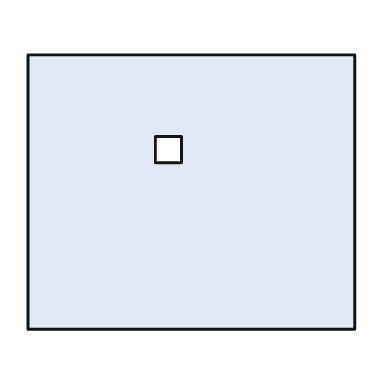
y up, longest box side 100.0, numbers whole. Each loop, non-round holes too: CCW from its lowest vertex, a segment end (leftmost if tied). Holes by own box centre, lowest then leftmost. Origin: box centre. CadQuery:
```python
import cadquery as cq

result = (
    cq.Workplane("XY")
    .moveTo(-50.0, -42.0)
    .lineTo(50.0, -42.0)
    .lineTo(50.0, 42.0)
    .lineTo(-50.0, 42.0)
    .close()
    .moveTo(-11.0, 9.0)
    .lineTo(-3.0, 9.0)
    .lineTo(-3.0, 17.0)
    .lineTo(-11.0, 17.0)
    .close()
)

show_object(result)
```